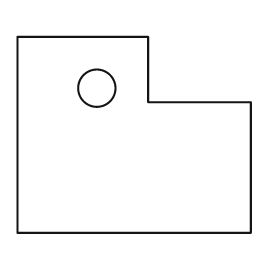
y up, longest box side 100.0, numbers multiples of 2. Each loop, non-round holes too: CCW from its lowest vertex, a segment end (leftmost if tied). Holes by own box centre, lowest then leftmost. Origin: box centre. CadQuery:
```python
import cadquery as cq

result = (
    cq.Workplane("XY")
    .moveTo(-50.0, -42.0)
    .lineTo(50.0, -42.0)
    .lineTo(50.0, 14.0)
    .lineTo(6.0, 14.0)
    .lineTo(6.0, 42.0)
    .lineTo(-50.0, 42.0)
    .close()
    .moveTo(-16.0, 20.0)
    .circle(8.0)
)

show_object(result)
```